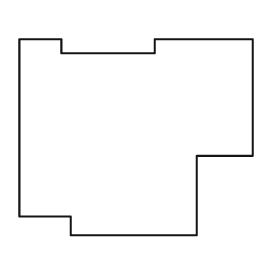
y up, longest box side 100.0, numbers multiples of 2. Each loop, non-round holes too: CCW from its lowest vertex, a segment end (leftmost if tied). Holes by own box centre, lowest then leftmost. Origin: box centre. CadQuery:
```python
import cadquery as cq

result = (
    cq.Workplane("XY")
    .moveTo(-28.0, -42.0)
    .lineTo(26.0, -42.0)
    .lineTo(26.0, -8.0)
    .lineTo(50.0, -8.0)
    .lineTo(50.0, 42.0)
    .lineTo(8.0, 42.0)
    .lineTo(8.0, 36.0)
    .lineTo(-32.0, 36.0)
    .lineTo(-32.0, 42.0)
    .lineTo(-50.0, 42.0)
    .lineTo(-50.0, -34.0)
    .lineTo(-28.0, -34.0)
    .close()
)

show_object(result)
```